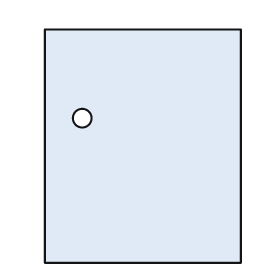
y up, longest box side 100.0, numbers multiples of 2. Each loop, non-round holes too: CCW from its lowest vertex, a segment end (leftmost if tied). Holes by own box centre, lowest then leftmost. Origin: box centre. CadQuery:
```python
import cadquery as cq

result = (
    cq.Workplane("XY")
    .moveTo(-42.0, -50.0)
    .lineTo(42.0, -50.0)
    .lineTo(42.0, 50.0)
    .lineTo(-42.0, 50.0)
    .close()
    .moveTo(-26.0, 12.0)
    .circle(4.0)
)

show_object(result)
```